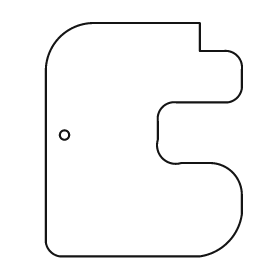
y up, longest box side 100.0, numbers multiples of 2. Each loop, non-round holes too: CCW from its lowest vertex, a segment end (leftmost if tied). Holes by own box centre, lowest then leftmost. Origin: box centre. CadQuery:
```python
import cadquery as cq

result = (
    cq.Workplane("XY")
    .moveTo(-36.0, -50.0)
    .lineTo(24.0, -50.0)
    .threePointArc((36.0, -44.0), (42.0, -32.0))
    .lineTo(42.0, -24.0)
    .threePointArc((38.0, -14.0), (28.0, -10.0))
    .lineTo(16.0, -10.0)
    .threePointArc((8.0, -8.0), (6.0, 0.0))
    .lineTo(6.0, 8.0)
    .threePointArc((8.0, 14.0), (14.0, 16.0))
    .lineTo(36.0, 16.0)
    .threePointArc((40.0, 18.0), (42.0, 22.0))
    .lineTo(42.0, 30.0)
    .threePointArc((40.0, 36.0), (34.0, 38.0))
    .lineTo(24.0, 38.0)
    .lineTo(24.0, 50.0)
    .lineTo(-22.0, 50.0)
    .threePointArc((-36.0, 44.0), (-42.0, 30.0))
    .lineTo(-42.0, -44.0)
    .threePointArc((-40.0, -48.0), (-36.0, -50.0))
    .close()
    .moveTo(-34.0, 2.0)
    .circle(2.0)
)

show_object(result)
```